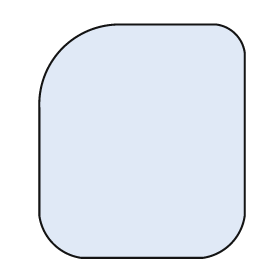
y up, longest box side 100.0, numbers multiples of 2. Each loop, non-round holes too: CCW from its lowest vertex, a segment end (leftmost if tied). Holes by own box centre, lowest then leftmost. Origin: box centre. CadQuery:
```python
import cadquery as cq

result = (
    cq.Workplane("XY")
    .moveTo(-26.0, -50.0)
    .lineTo(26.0, -50.0)
    .threePointArc((38.0, -44.0), (44.0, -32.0))
    .lineTo(44.0, 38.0)
    .threePointArc((40.0, 46.0), (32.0, 50.0))
    .lineTo(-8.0, 50.0)
    .threePointArc((-34.0, 40.0), (-44.0, 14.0))
    .lineTo(-44.0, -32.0)
    .threePointArc((-38.0, -44.0), (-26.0, -50.0))
    .close()
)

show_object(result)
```